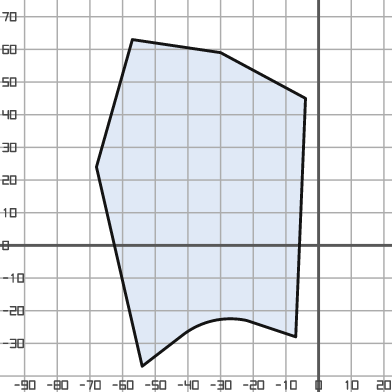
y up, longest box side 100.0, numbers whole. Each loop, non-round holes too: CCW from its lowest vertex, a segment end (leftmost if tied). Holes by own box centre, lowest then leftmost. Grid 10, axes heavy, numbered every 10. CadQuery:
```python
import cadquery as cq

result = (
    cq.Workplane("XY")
    .moveTo(-54.0, -37.0)
    .lineTo(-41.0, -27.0)
    .threePointArc((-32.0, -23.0), (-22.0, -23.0))
    .lineTo(-7.0, -28.0)
    .lineTo(-4.0, 45.0)
    .lineTo(-30.0, 59.0)
    .lineTo(-57.0, 63.0)
    .lineTo(-68.0, 24.0)
    .close()
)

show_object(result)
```